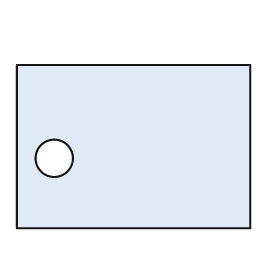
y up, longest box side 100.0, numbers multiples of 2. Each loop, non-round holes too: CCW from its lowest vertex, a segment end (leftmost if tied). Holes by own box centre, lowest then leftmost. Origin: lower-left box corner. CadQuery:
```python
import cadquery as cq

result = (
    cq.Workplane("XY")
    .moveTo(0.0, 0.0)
    .lineTo(100.0, 0.0)
    .lineTo(100.0, 70.0)
    .lineTo(0.0, 70.0)
    .close()
    .moveTo(16.0, 30.0)
    .circle(8.0)
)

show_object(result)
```